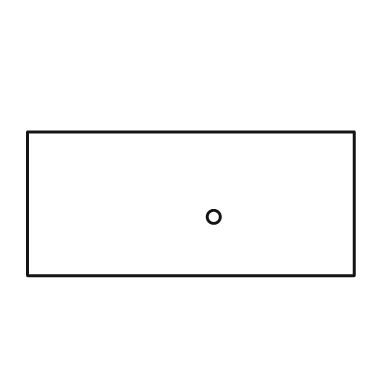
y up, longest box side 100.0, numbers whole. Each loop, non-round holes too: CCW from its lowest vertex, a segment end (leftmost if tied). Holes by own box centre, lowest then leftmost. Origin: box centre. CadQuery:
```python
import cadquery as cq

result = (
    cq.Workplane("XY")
    .moveTo(-50.0, -22.0)
    .lineTo(50.0, -22.0)
    .lineTo(50.0, 22.0)
    .lineTo(-50.0, 22.0)
    .close()
    .moveTo(7.0, -4.0)
    .circle(2.0)
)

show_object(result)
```